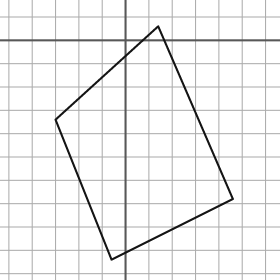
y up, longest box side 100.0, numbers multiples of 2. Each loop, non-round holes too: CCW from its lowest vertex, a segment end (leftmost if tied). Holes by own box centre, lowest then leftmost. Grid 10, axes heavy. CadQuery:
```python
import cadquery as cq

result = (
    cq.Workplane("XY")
    .moveTo(-6.0, -94.0)
    .lineTo(46.0, -68.0)
    .lineTo(14.0, 6.0)
    .lineTo(-30.0, -34.0)
    .close()
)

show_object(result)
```